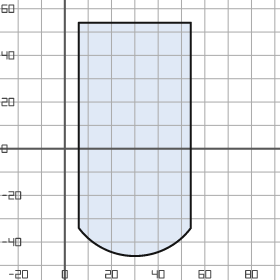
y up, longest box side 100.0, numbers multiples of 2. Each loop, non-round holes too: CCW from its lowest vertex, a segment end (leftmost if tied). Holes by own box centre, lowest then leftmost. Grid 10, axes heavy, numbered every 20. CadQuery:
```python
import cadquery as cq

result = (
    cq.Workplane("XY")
    .moveTo(6.0, -34.0)
    .threePointArc((30.0, -46.0), (54.0, -34.0))
    .lineTo(54.0, 54.0)
    .lineTo(6.0, 54.0)
    .close()
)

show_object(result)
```